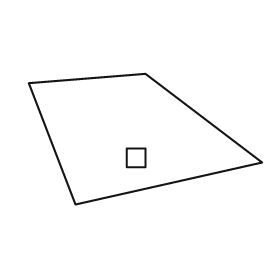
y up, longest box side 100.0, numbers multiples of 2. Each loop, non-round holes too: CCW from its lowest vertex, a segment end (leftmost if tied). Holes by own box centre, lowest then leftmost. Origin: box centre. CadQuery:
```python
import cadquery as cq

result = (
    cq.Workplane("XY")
    .moveTo(-30.0, -28.0)
    .lineTo(50.0, -10.0)
    .lineTo(0.0, 28.0)
    .lineTo(-50.0, 24.0)
    .close()
    .moveTo(-8.0, -12.0)
    .lineTo(0.0, -12.0)
    .lineTo(0.0, -4.0)
    .lineTo(-8.0, -4.0)
    .close()
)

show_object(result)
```